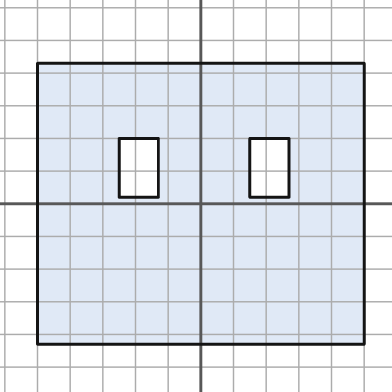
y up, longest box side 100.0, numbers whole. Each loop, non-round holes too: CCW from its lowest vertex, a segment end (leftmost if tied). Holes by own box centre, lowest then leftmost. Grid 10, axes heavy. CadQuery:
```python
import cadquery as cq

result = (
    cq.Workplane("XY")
    .moveTo(-50.0, -43.0)
    .lineTo(50.0, -43.0)
    .lineTo(50.0, 43.0)
    .lineTo(-50.0, 43.0)
    .close()
    .moveTo(-25.0, 2.0)
    .lineTo(-13.0, 2.0)
    .lineTo(-13.0, 20.0)
    .lineTo(-25.0, 20.0)
    .close()
    .moveTo(15.0, 2.0)
    .lineTo(27.0, 2.0)
    .lineTo(27.0, 20.0)
    .lineTo(15.0, 20.0)
    .close()
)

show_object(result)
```